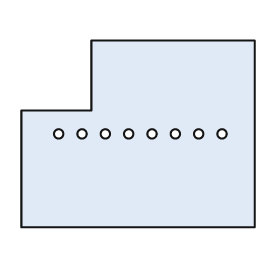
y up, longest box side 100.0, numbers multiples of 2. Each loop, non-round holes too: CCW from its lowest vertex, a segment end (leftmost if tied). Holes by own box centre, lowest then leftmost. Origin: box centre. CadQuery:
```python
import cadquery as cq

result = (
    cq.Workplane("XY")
    .moveTo(-50.0, -40.0)
    .lineTo(50.0, -40.0)
    .lineTo(50.0, 40.0)
    .lineTo(-20.0, 40.0)
    .lineTo(-20.0, 10.0)
    .lineTo(-50.0, 10.0)
    .close()
    .moveTo(-34.0, 0.0)
    .circle(2.0)
    .moveTo(-24.0, 0.0)
    .circle(2.0)
    .moveTo(-14.0, 0.0)
    .circle(2.0)
    .moveTo(-4.0, 0.0)
    .circle(2.0)
    .moveTo(6.0, 0.0)
    .circle(2.0)
    .moveTo(16.0, 0.0)
    .circle(2.0)
    .moveTo(26.0, 0.0)
    .circle(2.0)
    .moveTo(36.0, 0.0)
    .circle(2.0)
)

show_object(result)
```